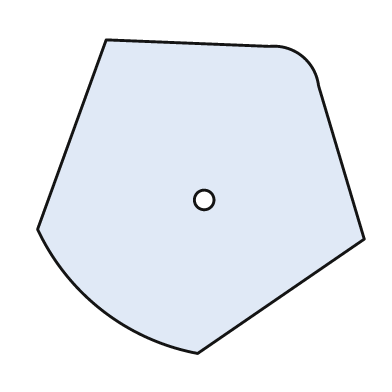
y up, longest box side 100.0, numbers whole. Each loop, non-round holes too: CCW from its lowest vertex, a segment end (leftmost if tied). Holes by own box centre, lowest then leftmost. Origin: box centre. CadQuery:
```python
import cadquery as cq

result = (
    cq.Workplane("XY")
    .moveTo(-1.0, -48.0)
    .lineTo(50.0, -13.0)
    .lineTo(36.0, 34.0)
    .threePointArc((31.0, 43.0), (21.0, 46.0))
    .lineTo(-29.0, 48.0)
    .lineTo(-50.0, -10.0)
    .threePointArc((-30.0, -35.0), (-1.0, -48.0))
    .close()
    .moveTo(1.0, -1.0)
    .circle(3.0)
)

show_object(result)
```